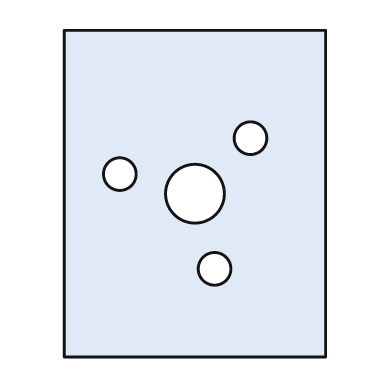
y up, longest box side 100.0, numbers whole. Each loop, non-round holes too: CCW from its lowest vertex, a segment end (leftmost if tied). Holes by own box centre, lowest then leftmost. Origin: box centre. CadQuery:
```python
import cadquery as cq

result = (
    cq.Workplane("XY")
    .moveTo(-40.0, -50.0)
    .lineTo(40.0, -50.0)
    .lineTo(40.0, 50.0)
    .lineTo(-40.0, 50.0)
    .close()
    .moveTo(6.0, -23.0)
    .circle(5.0)
    .moveTo(0.0, 0.0)
    .circle(9.0)
    .moveTo(-23.0, 6.0)
    .circle(5.0)
    .moveTo(17.0, 17.0)
    .circle(5.0)
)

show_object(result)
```